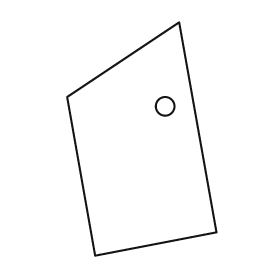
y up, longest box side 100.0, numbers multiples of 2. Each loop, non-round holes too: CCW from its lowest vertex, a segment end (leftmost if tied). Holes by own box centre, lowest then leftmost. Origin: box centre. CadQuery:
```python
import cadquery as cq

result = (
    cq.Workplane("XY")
    .moveTo(-20.0, -50.0)
    .lineTo(32.0, -40.0)
    .lineTo(16.0, 50.0)
    .lineTo(-32.0, 18.0)
    .close()
    .moveTo(10.0, 14.0)
    .circle(4.0)
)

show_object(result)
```